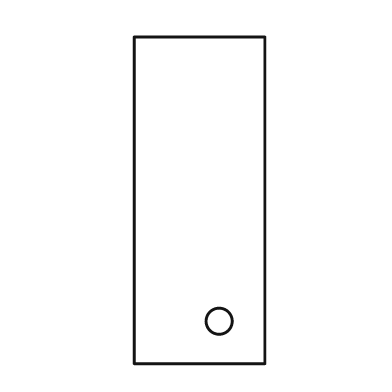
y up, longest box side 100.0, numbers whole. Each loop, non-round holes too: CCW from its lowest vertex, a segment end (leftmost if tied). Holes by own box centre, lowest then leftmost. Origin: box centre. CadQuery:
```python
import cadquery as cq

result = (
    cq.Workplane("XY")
    .moveTo(-20.0, -50.0)
    .lineTo(20.0, -50.0)
    .lineTo(20.0, 50.0)
    .lineTo(-20.0, 50.0)
    .close()
    .moveTo(6.0, -37.0)
    .circle(4.0)
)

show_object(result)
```